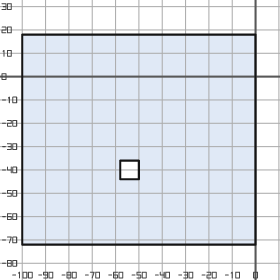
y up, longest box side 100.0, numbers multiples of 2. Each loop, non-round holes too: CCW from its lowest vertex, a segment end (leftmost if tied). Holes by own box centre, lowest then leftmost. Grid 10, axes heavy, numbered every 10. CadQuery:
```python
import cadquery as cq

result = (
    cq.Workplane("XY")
    .moveTo(-100.0, -72.0)
    .lineTo(0.0, -72.0)
    .lineTo(0.0, 18.0)
    .lineTo(-100.0, 18.0)
    .close()
    .moveTo(-58.0, -44.0)
    .lineTo(-50.0, -44.0)
    .lineTo(-50.0, -36.0)
    .lineTo(-58.0, -36.0)
    .close()
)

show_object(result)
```